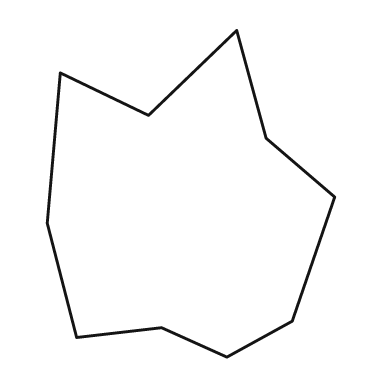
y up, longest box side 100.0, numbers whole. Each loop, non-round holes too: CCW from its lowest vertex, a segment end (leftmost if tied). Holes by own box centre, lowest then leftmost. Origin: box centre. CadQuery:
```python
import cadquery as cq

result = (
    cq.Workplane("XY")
    .moveTo(11.0, -50.0)
    .lineTo(31.0, -39.0)
    .lineTo(44.0, -1.0)
    .lineTo(23.0, 17.0)
    .lineTo(14.0, 50.0)
    .lineTo(-13.0, 24.0)
    .lineTo(-40.0, 37.0)
    .lineTo(-44.0, -9.0)
    .lineTo(-35.0, -44.0)
    .lineTo(-9.0, -41.0)
    .close()
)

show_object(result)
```